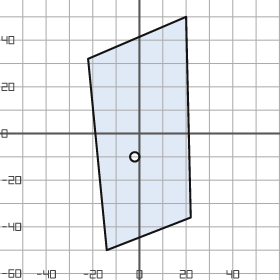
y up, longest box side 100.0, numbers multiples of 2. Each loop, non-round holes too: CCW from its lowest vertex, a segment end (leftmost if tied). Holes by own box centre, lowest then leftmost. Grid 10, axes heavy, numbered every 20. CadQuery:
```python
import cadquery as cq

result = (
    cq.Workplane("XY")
    .moveTo(-14.0, -50.0)
    .lineTo(22.0, -36.0)
    .lineTo(20.0, 50.0)
    .lineTo(-22.0, 32.0)
    .close()
    .moveTo(-2.0, -10.0)
    .circle(2.0)
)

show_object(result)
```